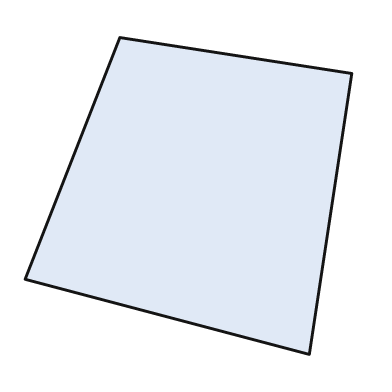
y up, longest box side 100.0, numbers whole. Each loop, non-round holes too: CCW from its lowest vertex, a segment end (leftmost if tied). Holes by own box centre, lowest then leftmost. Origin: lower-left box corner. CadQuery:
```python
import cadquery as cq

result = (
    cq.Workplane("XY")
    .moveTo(87.0, 0.0)
    .lineTo(100.0, 86.0)
    .lineTo(29.0, 97.0)
    .lineTo(0.0, 23.0)
    .close()
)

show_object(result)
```